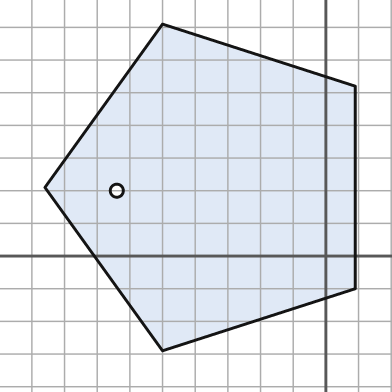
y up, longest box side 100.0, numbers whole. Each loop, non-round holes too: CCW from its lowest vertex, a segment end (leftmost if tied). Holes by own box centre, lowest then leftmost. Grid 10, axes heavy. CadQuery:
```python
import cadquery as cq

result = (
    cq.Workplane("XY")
    .moveTo(-50.0, -29.0)
    .lineTo(9.0, -10.0)
    .lineTo(9.0, 52.0)
    .lineTo(-50.0, 71.0)
    .lineTo(-86.0, 21.0)
    .close()
    .moveTo(-64.0, 20.0)
    .circle(2.0)
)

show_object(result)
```